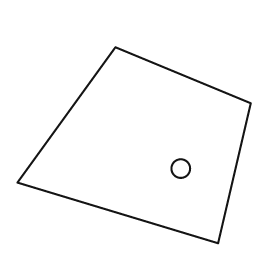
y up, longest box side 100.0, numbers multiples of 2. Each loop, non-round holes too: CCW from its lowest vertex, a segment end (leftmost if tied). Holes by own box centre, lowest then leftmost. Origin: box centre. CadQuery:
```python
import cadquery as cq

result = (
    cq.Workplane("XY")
    .moveTo(36.0, -42.0)
    .lineTo(50.0, 18.0)
    .lineTo(-8.0, 42.0)
    .lineTo(-50.0, -16.0)
    .close()
    .moveTo(20.0, -10.0)
    .circle(4.0)
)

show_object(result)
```